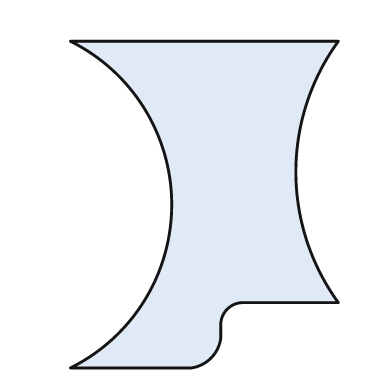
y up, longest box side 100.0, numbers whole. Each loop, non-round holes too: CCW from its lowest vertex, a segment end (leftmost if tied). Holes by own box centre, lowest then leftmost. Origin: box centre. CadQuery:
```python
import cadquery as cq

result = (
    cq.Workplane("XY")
    .moveTo(-41.0, -50.0)
    .lineTo(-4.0, -50.0)
    .threePointArc((2.0, -47.0), (5.0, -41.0))
    .lineTo(5.0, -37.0)
    .threePointArc((7.0, -32.0), (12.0, -30.0))
    .lineTo(41.0, -30.0)
    .threePointArc((28.0, 10.0), (41.0, 50.0))
    .lineTo(-41.0, 50.0)
    .threePointArc((-10.0, 0.0), (-41.0, -50.0))
    .close()
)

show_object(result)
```